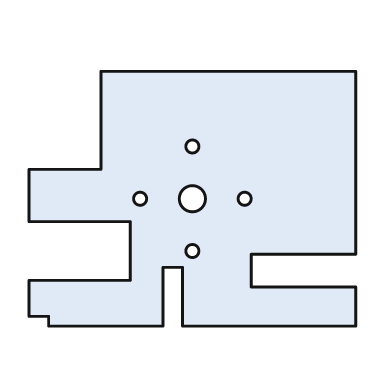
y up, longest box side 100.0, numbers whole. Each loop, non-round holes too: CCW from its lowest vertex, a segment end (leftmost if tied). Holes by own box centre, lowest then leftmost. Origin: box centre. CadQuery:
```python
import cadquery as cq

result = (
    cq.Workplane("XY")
    .moveTo(-44.0, -39.0)
    .lineTo(-9.0, -39.0)
    .lineTo(-9.0, -21.0)
    .lineTo(-3.0, -21.0)
    .lineTo(-3.0, -39.0)
    .lineTo(50.0, -39.0)
    .lineTo(50.0, -27.0)
    .lineTo(18.0, -27.0)
    .lineTo(18.0, -17.0)
    .lineTo(50.0, -17.0)
    .lineTo(50.0, 39.0)
    .lineTo(-28.0, 39.0)
    .lineTo(-28.0, 9.0)
    .lineTo(-50.0, 9.0)
    .lineTo(-50.0, -7.0)
    .lineTo(-19.0, -7.0)
    .lineTo(-19.0, -25.0)
    .lineTo(-50.0, -25.0)
    .lineTo(-50.0, -36.0)
    .lineTo(-44.0, -36.0)
    .close()
    .moveTo(0.0, -16.0)
    .circle(2.0)
    .moveTo(-16.0, 0.0)
    .circle(2.0)
    .moveTo(0.0, 0.0)
    .circle(4.0)
    .moveTo(16.0, 0.0)
    .circle(2.0)
    .moveTo(0.0, 16.0)
    .circle(2.0)
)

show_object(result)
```